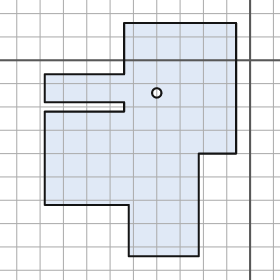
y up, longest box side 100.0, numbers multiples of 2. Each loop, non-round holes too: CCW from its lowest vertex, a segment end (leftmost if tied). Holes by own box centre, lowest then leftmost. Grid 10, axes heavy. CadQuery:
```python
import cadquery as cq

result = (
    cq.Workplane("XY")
    .moveTo(-52.0, -84.0)
    .lineTo(-22.0, -84.0)
    .lineTo(-22.0, -40.0)
    .lineTo(-6.0, -40.0)
    .lineTo(-6.0, 16.0)
    .lineTo(-54.0, 16.0)
    .lineTo(-54.0, -6.0)
    .lineTo(-88.0, -6.0)
    .lineTo(-88.0, -18.0)
    .lineTo(-54.0, -18.0)
    .lineTo(-54.0, -22.0)
    .lineTo(-88.0, -22.0)
    .lineTo(-88.0, -62.0)
    .lineTo(-52.0, -62.0)
    .close()
    .moveTo(-40.0, -14.0)
    .circle(2.0)
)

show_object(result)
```